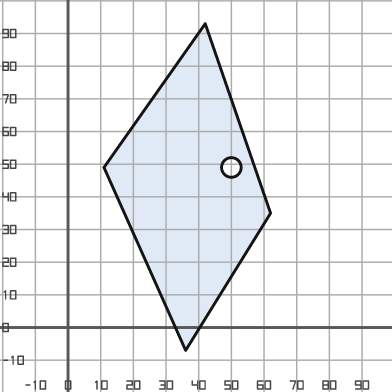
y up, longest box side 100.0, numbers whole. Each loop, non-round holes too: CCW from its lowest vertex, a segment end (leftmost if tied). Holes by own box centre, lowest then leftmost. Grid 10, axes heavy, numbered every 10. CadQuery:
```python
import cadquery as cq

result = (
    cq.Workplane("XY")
    .moveTo(36.0, -7.0)
    .lineTo(62.0, 35.0)
    .lineTo(42.0, 93.0)
    .lineTo(11.0, 49.0)
    .close()
    .moveTo(50.0, 49.0)
    .circle(3.0)
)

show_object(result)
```